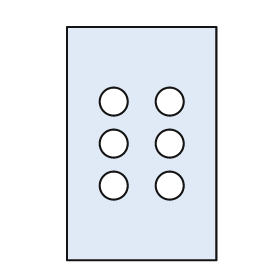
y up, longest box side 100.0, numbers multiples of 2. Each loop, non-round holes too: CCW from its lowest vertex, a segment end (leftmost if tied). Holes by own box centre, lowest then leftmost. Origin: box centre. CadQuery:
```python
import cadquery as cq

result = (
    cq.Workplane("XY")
    .moveTo(-32.0, -50.0)
    .lineTo(32.0, -50.0)
    .lineTo(32.0, 50.0)
    .lineTo(-32.0, 50.0)
    .close()
    .moveTo(-12.0, -18.0)
    .circle(6.0)
    .moveTo(12.0, -18.0)
    .circle(6.0)
    .moveTo(-12.0, 0.0)
    .circle(6.0)
    .moveTo(12.0, 0.0)
    .circle(6.0)
    .moveTo(-12.0, 18.0)
    .circle(6.0)
    .moveTo(12.0, 18.0)
    .circle(6.0)
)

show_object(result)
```